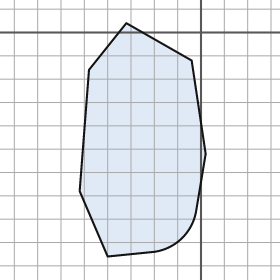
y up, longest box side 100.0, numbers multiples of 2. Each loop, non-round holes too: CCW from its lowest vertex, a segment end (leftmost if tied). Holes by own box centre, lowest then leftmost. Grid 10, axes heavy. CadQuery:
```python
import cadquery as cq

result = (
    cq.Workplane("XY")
    .moveTo(-40.0, -96.0)
    .lineTo(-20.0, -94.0)
    .threePointArc((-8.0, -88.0), (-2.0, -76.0))
    .lineTo(2.0, -52.0)
    .lineTo(-4.0, -12.0)
    .lineTo(-32.0, 4.0)
    .lineTo(-48.0, -16.0)
    .lineTo(-52.0, -68.0)
    .close()
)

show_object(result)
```